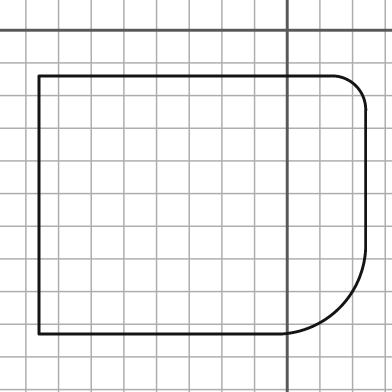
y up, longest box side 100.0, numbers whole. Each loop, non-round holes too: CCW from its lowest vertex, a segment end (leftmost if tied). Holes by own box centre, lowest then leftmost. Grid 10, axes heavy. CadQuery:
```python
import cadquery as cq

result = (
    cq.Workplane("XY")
    .moveTo(-76.0, -93.0)
    .lineTo(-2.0, -93.0)
    .threePointArc((16.0, -85.0), (24.0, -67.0))
    .lineTo(24.0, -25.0)
    .threePointArc((21.0, -17.0), (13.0, -14.0))
    .lineTo(-76.0, -14.0)
    .close()
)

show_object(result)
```